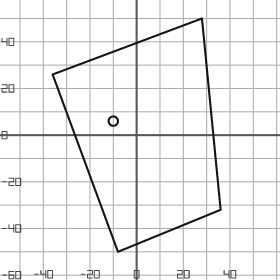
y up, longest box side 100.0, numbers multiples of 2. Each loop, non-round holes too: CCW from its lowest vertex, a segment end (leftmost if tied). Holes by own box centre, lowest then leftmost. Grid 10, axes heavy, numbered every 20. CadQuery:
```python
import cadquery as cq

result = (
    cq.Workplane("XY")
    .moveTo(-8.0, -50.0)
    .lineTo(36.0, -32.0)
    .lineTo(28.0, 50.0)
    .lineTo(-36.0, 26.0)
    .close()
    .moveTo(-10.0, 6.0)
    .circle(2.0)
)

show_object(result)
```